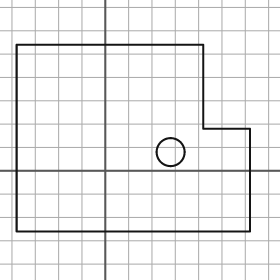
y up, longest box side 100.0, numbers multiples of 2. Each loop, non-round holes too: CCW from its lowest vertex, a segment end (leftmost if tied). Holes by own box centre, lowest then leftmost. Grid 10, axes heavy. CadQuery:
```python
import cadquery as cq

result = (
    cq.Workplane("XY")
    .moveTo(-38.0, -26.0)
    .lineTo(62.0, -26.0)
    .lineTo(62.0, 18.0)
    .lineTo(42.0, 18.0)
    .lineTo(42.0, 54.0)
    .lineTo(-38.0, 54.0)
    .close()
    .moveTo(28.0, 8.0)
    .circle(6.0)
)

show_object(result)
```